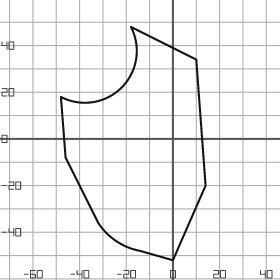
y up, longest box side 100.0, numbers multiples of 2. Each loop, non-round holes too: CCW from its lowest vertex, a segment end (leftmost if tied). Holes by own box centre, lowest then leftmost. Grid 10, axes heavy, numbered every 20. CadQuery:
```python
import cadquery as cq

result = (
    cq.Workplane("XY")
    .moveTo(0.0, -52.0)
    .lineTo(14.0, -20.0)
    .lineTo(10.0, 34.0)
    .lineTo(-18.0, 48.0)
    .threePointArc((-22.0, 22.0), (-48.0, 18.0))
    .lineTo(-46.0, -8.0)
    .lineTo(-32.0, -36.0)
    .threePointArc((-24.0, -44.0), (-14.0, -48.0))
    .close()
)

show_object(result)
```